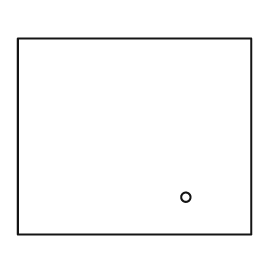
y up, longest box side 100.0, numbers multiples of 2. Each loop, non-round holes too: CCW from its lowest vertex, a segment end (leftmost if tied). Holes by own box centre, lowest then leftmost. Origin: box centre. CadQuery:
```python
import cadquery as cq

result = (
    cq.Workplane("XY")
    .moveTo(-50.0, -42.0)
    .lineTo(50.0, -42.0)
    .lineTo(50.0, 42.0)
    .lineTo(-50.0, 42.0)
    .close()
    .moveTo(22.0, -26.0)
    .circle(2.0)
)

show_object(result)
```